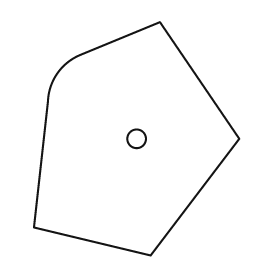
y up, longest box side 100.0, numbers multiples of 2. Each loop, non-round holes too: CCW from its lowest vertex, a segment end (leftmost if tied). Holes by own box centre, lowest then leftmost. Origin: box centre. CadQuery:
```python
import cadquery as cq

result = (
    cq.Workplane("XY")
    .moveTo(6.0, -50.0)
    .lineTo(44.0, 0.0)
    .lineTo(10.0, 50.0)
    .lineTo(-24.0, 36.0)
    .threePointArc((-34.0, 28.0), (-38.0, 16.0))
    .lineTo(-44.0, -38.0)
    .close()
    .moveTo(0.0, 0.0)
    .circle(4.0)
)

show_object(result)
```